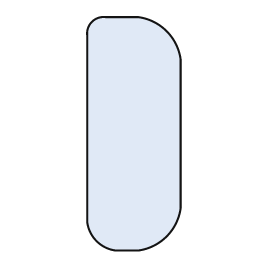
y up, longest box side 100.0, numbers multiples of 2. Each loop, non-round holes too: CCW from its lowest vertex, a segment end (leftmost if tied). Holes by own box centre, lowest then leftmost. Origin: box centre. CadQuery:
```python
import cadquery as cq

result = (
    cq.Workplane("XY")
    .moveTo(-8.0, -50.0)
    .lineTo(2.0, -50.0)
    .threePointArc((14.0, -44.0), (20.0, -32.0))
    .lineTo(20.0, 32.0)
    .threePointArc((14.0, 44.0), (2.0, 50.0))
    .lineTo(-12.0, 50.0)
    .threePointArc((-18.0, 48.0), (-20.0, 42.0))
    .lineTo(-20.0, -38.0)
    .threePointArc((-16.0, -46.0), (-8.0, -50.0))
    .close()
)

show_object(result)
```